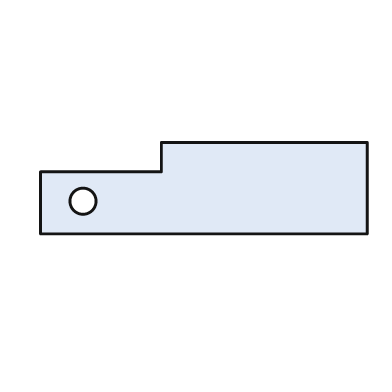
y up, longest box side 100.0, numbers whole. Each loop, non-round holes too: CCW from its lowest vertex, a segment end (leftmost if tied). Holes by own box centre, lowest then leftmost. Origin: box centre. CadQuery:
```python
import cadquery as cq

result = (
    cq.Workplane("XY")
    .moveTo(-50.0, -14.0)
    .lineTo(50.0, -14.0)
    .lineTo(50.0, 14.0)
    .lineTo(-13.0, 14.0)
    .lineTo(-13.0, 5.0)
    .lineTo(-50.0, 5.0)
    .close()
    .moveTo(-37.0, -4.0)
    .circle(4.0)
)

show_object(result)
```